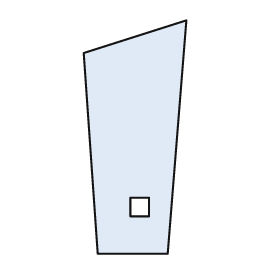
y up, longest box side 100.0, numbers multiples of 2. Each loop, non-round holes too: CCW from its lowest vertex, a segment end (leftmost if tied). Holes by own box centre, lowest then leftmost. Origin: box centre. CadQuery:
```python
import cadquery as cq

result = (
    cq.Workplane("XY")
    .moveTo(-16.0, -50.0)
    .lineTo(14.0, -50.0)
    .lineTo(22.0, 50.0)
    .lineTo(-22.0, 36.0)
    .close()
    .moveTo(-2.0, -34.0)
    .lineTo(6.0, -34.0)
    .lineTo(6.0, -26.0)
    .lineTo(-2.0, -26.0)
    .close()
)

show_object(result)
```